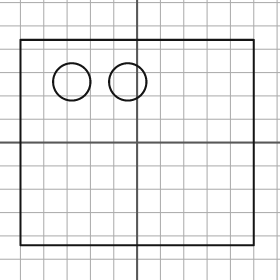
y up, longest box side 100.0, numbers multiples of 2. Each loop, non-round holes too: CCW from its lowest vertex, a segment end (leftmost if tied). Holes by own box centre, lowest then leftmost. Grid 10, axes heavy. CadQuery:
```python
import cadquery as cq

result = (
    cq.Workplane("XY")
    .moveTo(-50.0, -44.0)
    .lineTo(50.0, -44.0)
    .lineTo(50.0, 44.0)
    .lineTo(-50.0, 44.0)
    .close()
    .moveTo(-28.0, 26.0)
    .circle(8.0)
    .moveTo(-4.0, 26.0)
    .circle(8.0)
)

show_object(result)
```